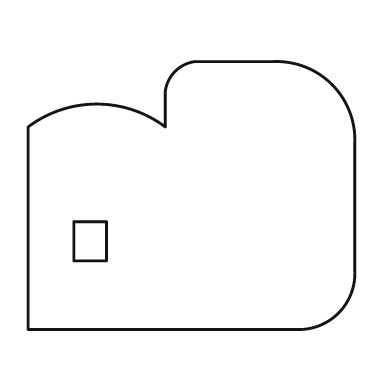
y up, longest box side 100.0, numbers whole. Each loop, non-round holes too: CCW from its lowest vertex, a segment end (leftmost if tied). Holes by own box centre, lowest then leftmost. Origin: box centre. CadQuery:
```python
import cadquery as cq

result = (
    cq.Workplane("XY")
    .moveTo(-50.0, -41.0)
    .lineTo(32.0, -41.0)
    .threePointArc((45.0, -36.0), (50.0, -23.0))
    .lineTo(50.0, 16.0)
    .threePointArc((43.0, 34.0), (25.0, 41.0))
    .lineTo(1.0, 41.0)
    .threePointArc((-5.0, 38.0), (-8.0, 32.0))
    .lineTo(-8.0, 21.0)
    .threePointArc((-29.0, 28.0), (-50.0, 21.0))
    .close()
    .moveTo(-36.0, -20.0)
    .lineTo(-26.0, -20.0)
    .lineTo(-26.0, -8.0)
    .lineTo(-36.0, -8.0)
    .close()
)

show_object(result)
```